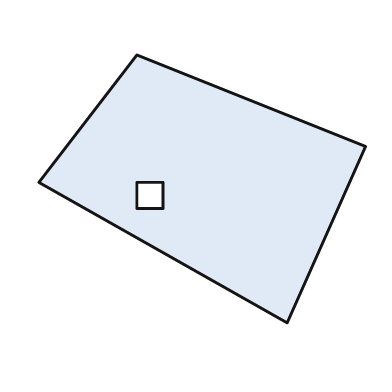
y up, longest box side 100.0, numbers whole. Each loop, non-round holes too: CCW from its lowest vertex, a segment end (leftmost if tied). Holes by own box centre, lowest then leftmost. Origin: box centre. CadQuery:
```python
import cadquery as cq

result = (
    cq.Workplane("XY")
    .moveTo(26.0, -41.0)
    .lineTo(50.0, 13.0)
    .lineTo(-20.0, 41.0)
    .lineTo(-50.0, 2.0)
    .close()
    .moveTo(-20.0, -6.0)
    .lineTo(-12.0, -6.0)
    .lineTo(-12.0, 2.0)
    .lineTo(-20.0, 2.0)
    .close()
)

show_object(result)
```